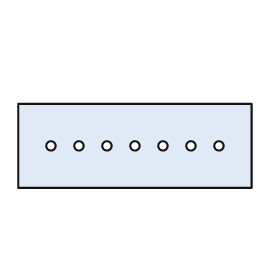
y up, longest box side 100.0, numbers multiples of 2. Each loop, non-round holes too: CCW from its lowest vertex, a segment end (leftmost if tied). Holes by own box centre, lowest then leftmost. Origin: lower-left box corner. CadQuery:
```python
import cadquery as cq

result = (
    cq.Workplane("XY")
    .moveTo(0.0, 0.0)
    .lineTo(100.0, 0.0)
    .lineTo(100.0, 36.0)
    .lineTo(0.0, 36.0)
    .close()
    .moveTo(14.0, 18.0)
    .circle(2.0)
    .moveTo(26.0, 18.0)
    .circle(2.0)
    .moveTo(38.0, 18.0)
    .circle(2.0)
    .moveTo(50.0, 18.0)
    .circle(2.0)
    .moveTo(62.0, 18.0)
    .circle(2.0)
    .moveTo(74.0, 18.0)
    .circle(2.0)
    .moveTo(86.0, 18.0)
    .circle(2.0)
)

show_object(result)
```